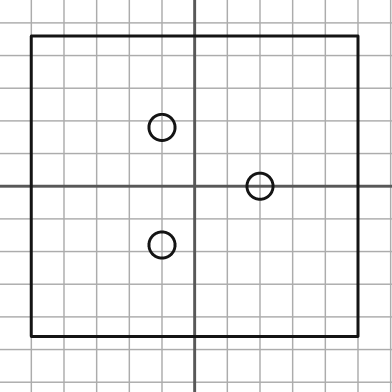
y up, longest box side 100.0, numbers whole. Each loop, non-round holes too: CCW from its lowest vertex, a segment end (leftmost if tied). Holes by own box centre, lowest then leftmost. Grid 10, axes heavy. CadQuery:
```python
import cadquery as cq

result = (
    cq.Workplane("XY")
    .moveTo(-50.0, -46.0)
    .lineTo(50.0, -46.0)
    .lineTo(50.0, 46.0)
    .lineTo(-50.0, 46.0)
    .close()
    .moveTo(-10.0, -18.0)
    .circle(4.0)
    .moveTo(20.0, 0.0)
    .circle(4.0)
    .moveTo(-10.0, 18.0)
    .circle(4.0)
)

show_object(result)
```